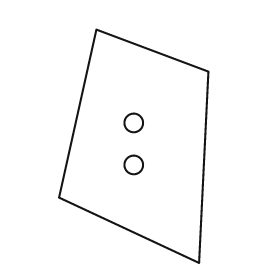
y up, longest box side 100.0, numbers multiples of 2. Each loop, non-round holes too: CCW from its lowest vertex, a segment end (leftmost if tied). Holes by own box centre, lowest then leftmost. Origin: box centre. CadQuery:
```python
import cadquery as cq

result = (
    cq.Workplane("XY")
    .moveTo(28.0, -50.0)
    .lineTo(32.0, 32.0)
    .lineTo(-16.0, 50.0)
    .lineTo(-32.0, -22.0)
    .close()
    .moveTo(0.0, -8.0)
    .circle(4.0)
    .moveTo(0.0, 10.0)
    .circle(4.0)
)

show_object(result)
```